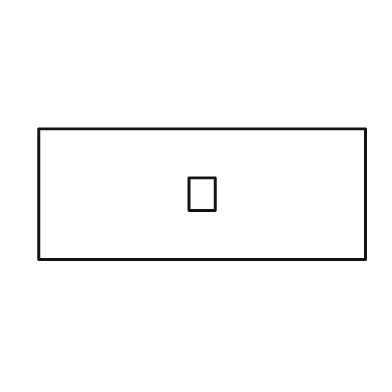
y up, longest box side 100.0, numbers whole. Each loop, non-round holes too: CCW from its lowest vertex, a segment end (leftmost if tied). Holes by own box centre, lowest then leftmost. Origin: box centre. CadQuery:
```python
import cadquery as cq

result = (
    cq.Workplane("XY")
    .moveTo(-50.0, -20.0)
    .lineTo(50.0, -20.0)
    .lineTo(50.0, 20.0)
    .lineTo(-50.0, 20.0)
    .close()
    .moveTo(-4.0, -5.0)
    .lineTo(4.0, -5.0)
    .lineTo(4.0, 5.0)
    .lineTo(-4.0, 5.0)
    .close()
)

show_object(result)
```